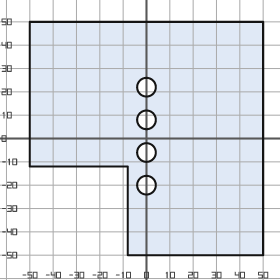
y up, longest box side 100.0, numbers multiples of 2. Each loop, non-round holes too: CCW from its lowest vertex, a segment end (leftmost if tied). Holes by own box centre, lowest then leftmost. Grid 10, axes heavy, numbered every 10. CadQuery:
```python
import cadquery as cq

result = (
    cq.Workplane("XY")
    .moveTo(-8.0, -50.0)
    .lineTo(50.0, -50.0)
    .lineTo(50.0, 50.0)
    .lineTo(-50.0, 50.0)
    .lineTo(-50.0, -12.0)
    .lineTo(-8.0, -12.0)
    .close()
    .moveTo(0.0, -20.0)
    .circle(4.0)
    .moveTo(0.0, -6.0)
    .circle(4.0)
    .moveTo(0.0, 8.0)
    .circle(4.0)
    .moveTo(0.0, 22.0)
    .circle(4.0)
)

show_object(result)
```